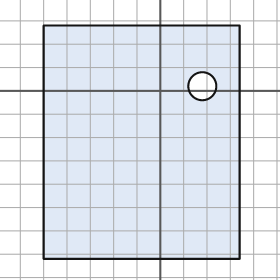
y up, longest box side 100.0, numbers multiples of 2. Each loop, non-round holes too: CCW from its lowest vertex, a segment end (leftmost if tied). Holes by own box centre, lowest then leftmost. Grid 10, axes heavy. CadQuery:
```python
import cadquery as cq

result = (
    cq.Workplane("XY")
    .moveTo(-50.0, -72.0)
    .lineTo(34.0, -72.0)
    .lineTo(34.0, 28.0)
    .lineTo(-50.0, 28.0)
    .close()
    .moveTo(18.0, 2.0)
    .circle(6.0)
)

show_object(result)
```